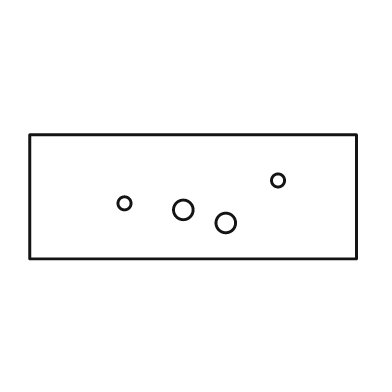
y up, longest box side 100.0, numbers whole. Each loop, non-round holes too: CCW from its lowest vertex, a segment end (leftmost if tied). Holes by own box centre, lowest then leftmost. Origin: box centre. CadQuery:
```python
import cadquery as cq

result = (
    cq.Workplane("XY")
    .moveTo(-50.0, -19.0)
    .lineTo(50.0, -19.0)
    .lineTo(50.0, 19.0)
    .lineTo(-50.0, 19.0)
    .close()
    .moveTo(10.0, -8.0)
    .circle(3.0)
    .moveTo(-3.0, -4.0)
    .circle(3.0)
    .moveTo(-21.0, -2.0)
    .circle(2.0)
    .moveTo(26.0, 5.0)
    .circle(2.0)
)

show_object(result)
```